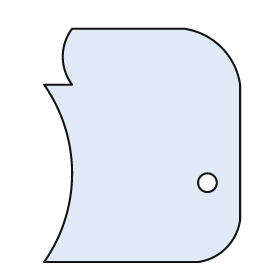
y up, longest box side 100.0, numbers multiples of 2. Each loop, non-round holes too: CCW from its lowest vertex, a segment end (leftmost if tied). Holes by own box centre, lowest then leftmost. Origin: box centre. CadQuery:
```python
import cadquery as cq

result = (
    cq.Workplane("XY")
    .moveTo(-42.0, -50.0)
    .lineTo(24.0, -50.0)
    .threePointArc((36.0, -44.0), (42.0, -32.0))
    .lineTo(42.0, 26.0)
    .threePointArc((34.0, 42.0), (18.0, 50.0))
    .lineTo(-30.0, 50.0)
    .threePointArc((-34.0, 38.0), (-30.0, 26.0))
    .lineTo(-42.0, 26.0)
    .threePointArc((-30.0, -12.0), (-42.0, -50.0))
    .close()
    .moveTo(28.0, -16.0)
    .circle(4.0)
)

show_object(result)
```